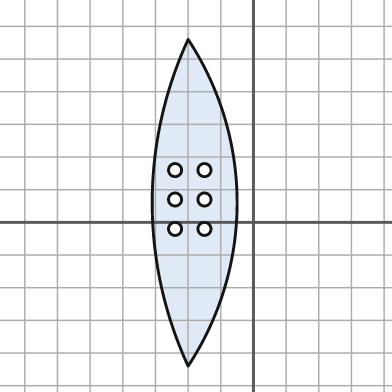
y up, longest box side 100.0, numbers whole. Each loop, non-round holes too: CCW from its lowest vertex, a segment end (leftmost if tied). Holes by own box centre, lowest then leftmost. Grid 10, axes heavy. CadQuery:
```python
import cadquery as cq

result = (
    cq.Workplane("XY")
    .moveTo(-20.0, -44.0)
    .threePointArc((-5.0, 6.0), (-20.0, 56.0))
    .threePointArc((-31.0, 6.0), (-20.0, -44.0))
    .close()
    .moveTo(-24.0, -2.0)
    .circle(2.0)
    .moveTo(-15.0, -2.0)
    .circle(2.0)
    .moveTo(-24.0, 7.0)
    .circle(2.0)
    .moveTo(-15.0, 7.0)
    .circle(2.0)
    .moveTo(-24.0, 16.0)
    .circle(2.0)
    .moveTo(-15.0, 16.0)
    .circle(2.0)
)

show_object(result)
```